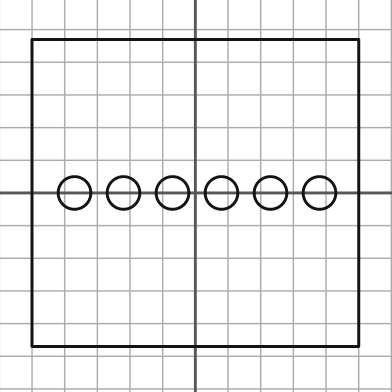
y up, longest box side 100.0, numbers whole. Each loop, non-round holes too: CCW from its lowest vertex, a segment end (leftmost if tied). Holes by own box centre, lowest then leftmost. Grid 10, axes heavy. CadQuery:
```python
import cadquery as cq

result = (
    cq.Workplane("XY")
    .moveTo(-50.0, -47.0)
    .lineTo(50.0, -47.0)
    .lineTo(50.0, 47.0)
    .lineTo(-50.0, 47.0)
    .close()
    .moveTo(-37.0, 0.0)
    .circle(5.0)
    .moveTo(-22.0, 0.0)
    .circle(5.0)
    .moveTo(-7.0, 0.0)
    .circle(5.0)
    .moveTo(8.0, 0.0)
    .circle(5.0)
    .moveTo(23.0, 0.0)
    .circle(5.0)
    .moveTo(38.0, 0.0)
    .circle(5.0)
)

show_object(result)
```